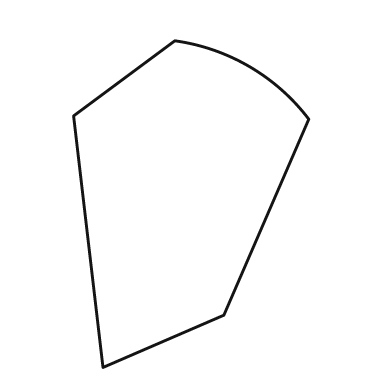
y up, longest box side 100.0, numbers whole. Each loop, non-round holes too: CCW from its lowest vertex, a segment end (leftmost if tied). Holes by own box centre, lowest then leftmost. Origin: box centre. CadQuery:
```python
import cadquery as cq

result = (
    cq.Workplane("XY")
    .moveTo(-27.0, -50.0)
    .lineTo(10.0, -34.0)
    .lineTo(36.0, 26.0)
    .threePointArc((18.0, 42.0), (-5.0, 50.0))
    .lineTo(-36.0, 27.0)
    .close()
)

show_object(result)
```